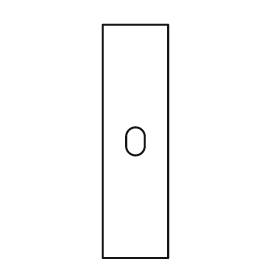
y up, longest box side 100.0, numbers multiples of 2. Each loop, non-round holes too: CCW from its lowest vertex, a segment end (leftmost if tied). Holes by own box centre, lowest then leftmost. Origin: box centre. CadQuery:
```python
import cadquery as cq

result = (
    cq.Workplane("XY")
    .moveTo(-14.0, -50.0)
    .lineTo(14.0, -50.0)
    .lineTo(14.0, 50.0)
    .lineTo(-14.0, 50.0)
    .close()
    .moveTo(-4.0, -2.0)
    .threePointArc((0.0, -6.0), (4.0, -2.0))
    .lineTo(4.0, 2.0)
    .threePointArc((0.0, 6.0), (-4.0, 2.0))
    .close()
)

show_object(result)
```